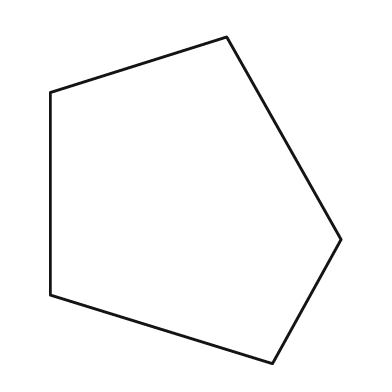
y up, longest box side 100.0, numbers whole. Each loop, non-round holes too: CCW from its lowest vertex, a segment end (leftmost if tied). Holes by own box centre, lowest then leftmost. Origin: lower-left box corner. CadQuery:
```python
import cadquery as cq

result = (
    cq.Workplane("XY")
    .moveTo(68.0, 0.0)
    .lineTo(89.0, 38.0)
    .lineTo(54.0, 100.0)
    .lineTo(0.0, 83.0)
    .lineTo(0.0, 21.0)
    .close()
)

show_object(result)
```